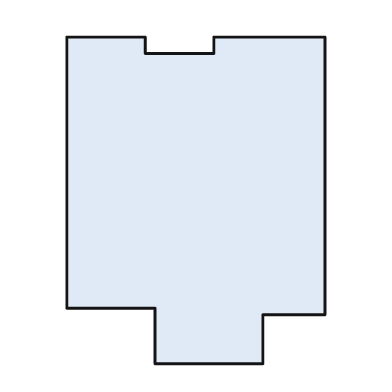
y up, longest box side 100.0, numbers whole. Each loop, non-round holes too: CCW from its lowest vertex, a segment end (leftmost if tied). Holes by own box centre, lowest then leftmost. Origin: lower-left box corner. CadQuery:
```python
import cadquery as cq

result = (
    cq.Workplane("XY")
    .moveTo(27.0, 0.0)
    .lineTo(60.0, 0.0)
    .lineTo(60.0, 15.0)
    .lineTo(79.0, 15.0)
    .lineTo(79.0, 100.0)
    .lineTo(45.0, 100.0)
    .lineTo(45.0, 95.0)
    .lineTo(24.0, 95.0)
    .lineTo(24.0, 100.0)
    .lineTo(0.0, 100.0)
    .lineTo(0.0, 17.0)
    .lineTo(27.0, 17.0)
    .close()
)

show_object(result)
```